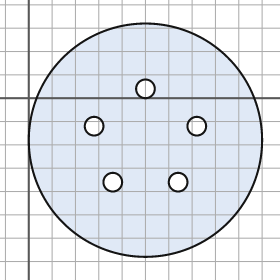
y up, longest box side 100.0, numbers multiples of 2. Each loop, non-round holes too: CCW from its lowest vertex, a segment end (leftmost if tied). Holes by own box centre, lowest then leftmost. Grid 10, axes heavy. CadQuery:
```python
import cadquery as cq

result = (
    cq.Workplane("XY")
    .moveTo(50.0, -18.0)
    .circle(50.0)
    .moveTo(36.0, -36.0)
    .circle(4.0)
    .moveTo(64.0, -36.0)
    .circle(4.0)
    .moveTo(28.0, -12.0)
    .circle(4.0)
    .moveTo(72.0, -12.0)
    .circle(4.0)
    .moveTo(50.0, 4.0)
    .circle(4.0)
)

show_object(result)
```